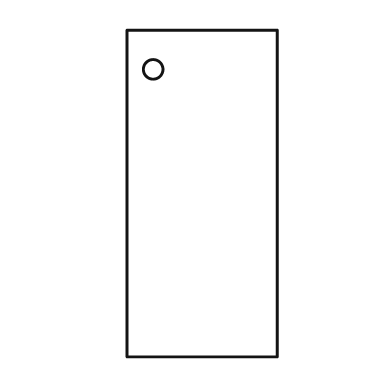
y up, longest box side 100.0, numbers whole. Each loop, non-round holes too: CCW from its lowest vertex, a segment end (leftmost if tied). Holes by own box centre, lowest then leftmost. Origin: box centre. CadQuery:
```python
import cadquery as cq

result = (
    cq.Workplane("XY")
    .moveTo(-23.0, -50.0)
    .lineTo(23.0, -50.0)
    .lineTo(23.0, 50.0)
    .lineTo(-23.0, 50.0)
    .close()
    .moveTo(-15.0, 38.0)
    .circle(3.0)
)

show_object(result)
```